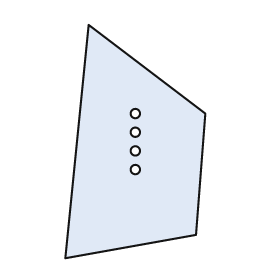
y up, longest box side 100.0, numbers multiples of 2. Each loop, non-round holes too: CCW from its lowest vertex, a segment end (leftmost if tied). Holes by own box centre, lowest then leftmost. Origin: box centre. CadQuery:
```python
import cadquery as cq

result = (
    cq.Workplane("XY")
    .moveTo(-30.0, -50.0)
    .lineTo(26.0, -40.0)
    .lineTo(30.0, 12.0)
    .lineTo(-20.0, 50.0)
    .close()
    .moveTo(0.0, -12.0)
    .circle(2.0)
    .moveTo(0.0, -4.0)
    .circle(2.0)
    .moveTo(0.0, 4.0)
    .circle(2.0)
    .moveTo(0.0, 12.0)
    .circle(2.0)
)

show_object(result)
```